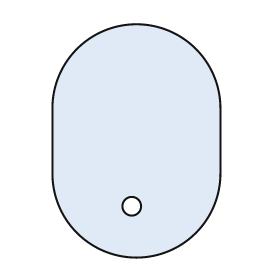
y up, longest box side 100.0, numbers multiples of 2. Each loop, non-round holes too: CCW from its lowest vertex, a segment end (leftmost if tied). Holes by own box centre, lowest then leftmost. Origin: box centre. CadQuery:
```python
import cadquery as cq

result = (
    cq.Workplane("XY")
    .moveTo(-36.0, -14.0)
    .threePointArc((0.0, -50.0), (36.0, -14.0))
    .lineTo(36.0, 14.0)
    .threePointArc((0.0, 50.0), (-36.0, 14.0))
    .close()
    .moveTo(-2.0, -28.0)
    .circle(4.0)
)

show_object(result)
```